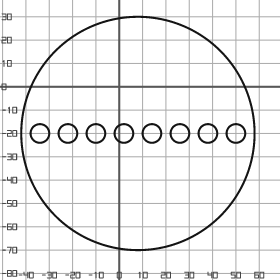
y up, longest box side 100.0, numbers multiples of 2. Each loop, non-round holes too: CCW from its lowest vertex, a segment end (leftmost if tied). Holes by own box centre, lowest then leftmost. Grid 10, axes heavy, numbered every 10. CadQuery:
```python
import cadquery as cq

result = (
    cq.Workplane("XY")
    .moveTo(8.0, -20.0)
    .circle(50.0)
    .moveTo(-34.0, -20.0)
    .circle(4.0)
    .moveTo(-22.0, -20.0)
    .circle(4.0)
    .moveTo(-10.0, -20.0)
    .circle(4.0)
    .moveTo(2.0, -20.0)
    .circle(4.0)
    .moveTo(14.0, -20.0)
    .circle(4.0)
    .moveTo(26.0, -20.0)
    .circle(4.0)
    .moveTo(38.0, -20.0)
    .circle(4.0)
    .moveTo(50.0, -20.0)
    .circle(4.0)
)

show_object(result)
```